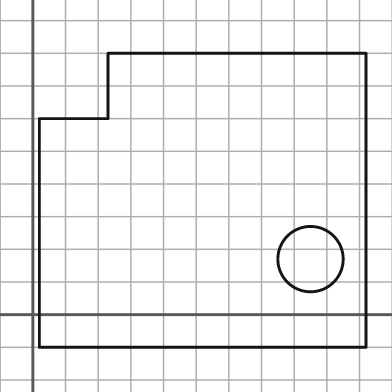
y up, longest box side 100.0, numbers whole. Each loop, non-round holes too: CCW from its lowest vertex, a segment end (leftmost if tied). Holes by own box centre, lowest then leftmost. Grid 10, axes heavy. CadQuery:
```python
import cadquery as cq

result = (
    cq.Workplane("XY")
    .moveTo(2.0, -10.0)
    .lineTo(102.0, -10.0)
    .lineTo(102.0, 80.0)
    .lineTo(23.0, 80.0)
    .lineTo(23.0, 60.0)
    .lineTo(2.0, 60.0)
    .close()
    .moveTo(85.0, 17.0)
    .circle(10.0)
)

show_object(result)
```